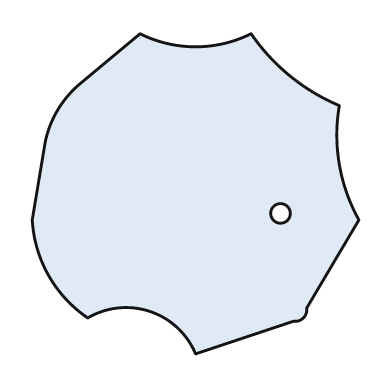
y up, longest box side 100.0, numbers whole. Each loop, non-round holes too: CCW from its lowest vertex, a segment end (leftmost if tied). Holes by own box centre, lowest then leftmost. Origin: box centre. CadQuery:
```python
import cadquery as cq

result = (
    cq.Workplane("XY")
    .moveTo(0.0, -49.0)
    .lineTo(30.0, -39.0)
    .threePointArc((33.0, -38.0), (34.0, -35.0))
    .lineTo(50.0, -8.0)
    .threePointArc((44.0, 9.0), (44.0, 27.0))
    .threePointArc((29.0, 36.0), (17.0, 49.0))
    .threePointArc((0.0, 45.0), (-17.0, 49.0))
    .lineTo(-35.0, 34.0)
    .threePointArc((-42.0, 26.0), (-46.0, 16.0))
    .lineTo(-50.0, -8.0)
    .threePointArc((-45.0, -25.0), (-33.0, -38.0))
    .threePointArc((-14.0, -36.0), (0.0, -49.0))
    .close()
    .moveTo(26.0, -6.0)
    .circle(3.0)
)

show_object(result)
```